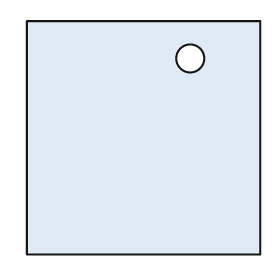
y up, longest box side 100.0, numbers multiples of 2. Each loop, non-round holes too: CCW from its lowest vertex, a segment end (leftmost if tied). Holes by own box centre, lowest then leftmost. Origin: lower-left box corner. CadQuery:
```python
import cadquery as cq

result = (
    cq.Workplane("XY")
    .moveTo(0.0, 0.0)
    .lineTo(100.0, 0.0)
    .lineTo(100.0, 100.0)
    .lineTo(0.0, 100.0)
    .close()
    .moveTo(70.0, 84.0)
    .circle(6.0)
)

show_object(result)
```